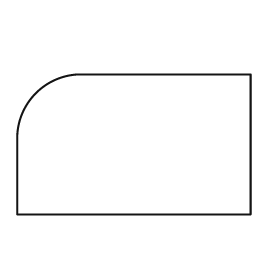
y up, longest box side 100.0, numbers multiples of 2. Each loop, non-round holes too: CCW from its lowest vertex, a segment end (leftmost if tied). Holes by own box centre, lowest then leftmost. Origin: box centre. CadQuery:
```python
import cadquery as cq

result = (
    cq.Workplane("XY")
    .moveTo(-50.0, -30.0)
    .lineTo(50.0, -30.0)
    .lineTo(50.0, 30.0)
    .lineTo(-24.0, 30.0)
    .threePointArc((-42.0, 22.0), (-50.0, 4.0))
    .close()
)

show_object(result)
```